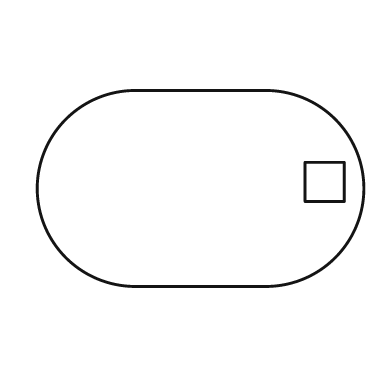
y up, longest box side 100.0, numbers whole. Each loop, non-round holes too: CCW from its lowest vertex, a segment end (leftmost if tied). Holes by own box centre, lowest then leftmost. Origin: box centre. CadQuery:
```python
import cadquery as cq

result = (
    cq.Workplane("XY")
    .moveTo(-20.0, -30.0)
    .lineTo(20.0, -30.0)
    .threePointArc((50.0, 0.0), (20.0, 30.0))
    .lineTo(-20.0, 30.0)
    .threePointArc((-50.0, 0.0), (-20.0, -30.0))
    .close()
    .moveTo(32.0, -4.0)
    .lineTo(44.0, -4.0)
    .lineTo(44.0, 8.0)
    .lineTo(32.0, 8.0)
    .close()
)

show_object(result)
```